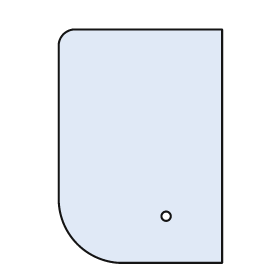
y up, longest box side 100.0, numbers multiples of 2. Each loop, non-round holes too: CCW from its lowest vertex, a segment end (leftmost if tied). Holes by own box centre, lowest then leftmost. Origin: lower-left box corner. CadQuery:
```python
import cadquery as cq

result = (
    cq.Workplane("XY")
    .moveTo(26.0, 0.0)
    .lineTo(70.0, 0.0)
    .lineTo(70.0, 100.0)
    .lineTo(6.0, 100.0)
    .threePointArc((2.0, 98.0), (0.0, 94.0))
    .lineTo(0.0, 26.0)
    .threePointArc((8.0, 8.0), (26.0, 0.0))
    .close()
    .moveTo(46.0, 20.0)
    .circle(2.0)
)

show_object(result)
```